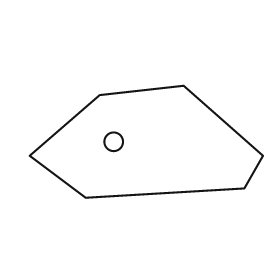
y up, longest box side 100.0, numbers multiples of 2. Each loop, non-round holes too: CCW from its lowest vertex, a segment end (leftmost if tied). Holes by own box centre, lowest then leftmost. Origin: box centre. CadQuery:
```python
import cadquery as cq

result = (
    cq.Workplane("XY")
    .moveTo(-26.0, -24.0)
    .lineTo(42.0, -20.0)
    .lineTo(50.0, -6.0)
    .lineTo(16.0, 24.0)
    .lineTo(-20.0, 20.0)
    .lineTo(-50.0, -6.0)
    .close()
    .moveTo(-14.0, 0.0)
    .circle(4.0)
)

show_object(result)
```